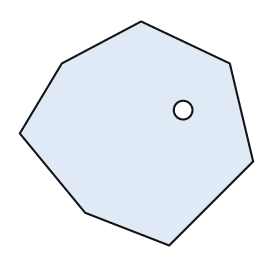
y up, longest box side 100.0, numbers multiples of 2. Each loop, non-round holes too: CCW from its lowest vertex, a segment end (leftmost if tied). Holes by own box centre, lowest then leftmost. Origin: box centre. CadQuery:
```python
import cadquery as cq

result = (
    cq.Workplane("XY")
    .moveTo(14.0, -48.0)
    .lineTo(50.0, -12.0)
    .lineTo(40.0, 30.0)
    .lineTo(2.0, 48.0)
    .lineTo(-32.0, 30.0)
    .lineTo(-50.0, 0.0)
    .lineTo(-22.0, -34.0)
    .close()
    .moveTo(20.0, 10.0)
    .circle(4.0)
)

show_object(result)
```